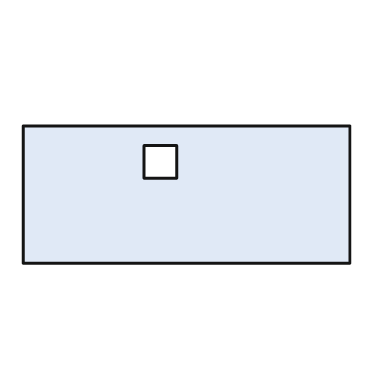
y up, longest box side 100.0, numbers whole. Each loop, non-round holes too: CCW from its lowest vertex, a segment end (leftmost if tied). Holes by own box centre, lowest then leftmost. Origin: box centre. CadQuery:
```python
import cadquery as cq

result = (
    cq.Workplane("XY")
    .moveTo(-50.0, -21.0)
    .lineTo(50.0, -21.0)
    .lineTo(50.0, 21.0)
    .lineTo(-50.0, 21.0)
    .close()
    .moveTo(-13.0, 5.0)
    .lineTo(-3.0, 5.0)
    .lineTo(-3.0, 15.0)
    .lineTo(-13.0, 15.0)
    .close()
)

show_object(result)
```